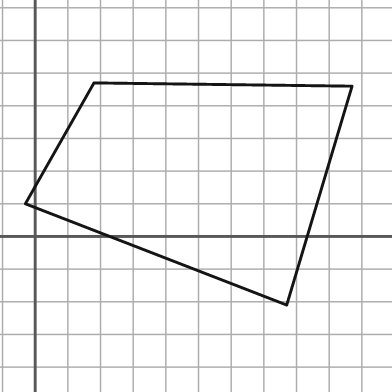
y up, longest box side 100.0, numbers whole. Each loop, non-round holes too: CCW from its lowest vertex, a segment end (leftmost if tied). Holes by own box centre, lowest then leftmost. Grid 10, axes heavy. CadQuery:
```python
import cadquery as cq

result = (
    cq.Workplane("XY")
    .moveTo(77.0, -21.0)
    .lineTo(97.0, 46.0)
    .lineTo(18.0, 47.0)
    .lineTo(-3.0, 10.0)
    .close()
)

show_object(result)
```